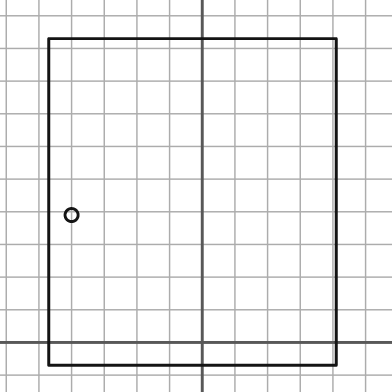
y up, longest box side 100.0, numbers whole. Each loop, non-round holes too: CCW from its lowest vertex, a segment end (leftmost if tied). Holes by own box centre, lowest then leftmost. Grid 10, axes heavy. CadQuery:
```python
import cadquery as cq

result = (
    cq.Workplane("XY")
    .moveTo(-47.0, -7.0)
    .lineTo(41.0, -7.0)
    .lineTo(41.0, 93.0)
    .lineTo(-47.0, 93.0)
    .close()
    .moveTo(-40.0, 39.0)
    .circle(2.0)
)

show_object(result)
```